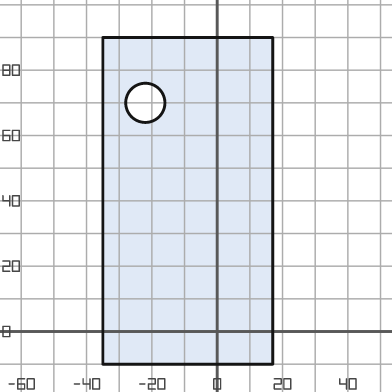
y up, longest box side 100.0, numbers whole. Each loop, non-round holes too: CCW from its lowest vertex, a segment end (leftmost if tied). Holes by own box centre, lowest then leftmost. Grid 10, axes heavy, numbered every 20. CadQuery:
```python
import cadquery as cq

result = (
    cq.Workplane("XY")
    .moveTo(-35.0, -10.0)
    .lineTo(17.0, -10.0)
    .lineTo(17.0, 90.0)
    .lineTo(-35.0, 90.0)
    .close()
    .moveTo(-22.0, 70.0)
    .circle(6.0)
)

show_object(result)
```